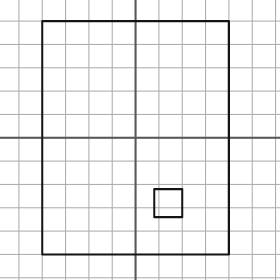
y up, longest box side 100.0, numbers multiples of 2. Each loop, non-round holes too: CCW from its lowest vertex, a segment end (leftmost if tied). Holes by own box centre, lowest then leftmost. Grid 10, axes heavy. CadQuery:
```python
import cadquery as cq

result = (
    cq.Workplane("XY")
    .moveTo(-40.0, -50.0)
    .lineTo(40.0, -50.0)
    .lineTo(40.0, 50.0)
    .lineTo(-40.0, 50.0)
    .close()
    .moveTo(8.0, -34.0)
    .lineTo(20.0, -34.0)
    .lineTo(20.0, -22.0)
    .lineTo(8.0, -22.0)
    .close()
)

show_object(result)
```